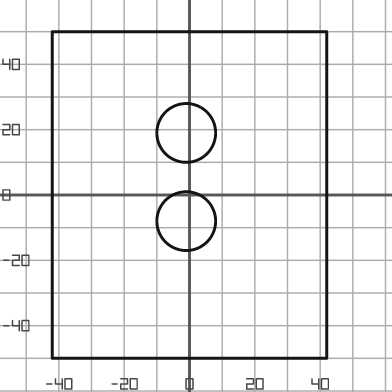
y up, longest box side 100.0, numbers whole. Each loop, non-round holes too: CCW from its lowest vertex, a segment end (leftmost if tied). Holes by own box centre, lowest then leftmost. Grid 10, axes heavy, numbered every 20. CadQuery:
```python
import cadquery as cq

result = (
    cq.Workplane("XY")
    .moveTo(-42.0, -50.0)
    .lineTo(42.0, -50.0)
    .lineTo(42.0, 50.0)
    .lineTo(-42.0, 50.0)
    .close()
    .moveTo(-1.0, -8.0)
    .circle(9.0)
    .moveTo(-1.0, 19.0)
    .circle(9.0)
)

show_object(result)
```